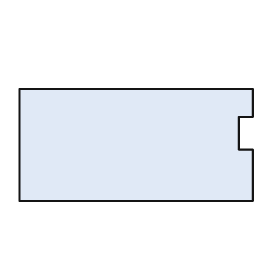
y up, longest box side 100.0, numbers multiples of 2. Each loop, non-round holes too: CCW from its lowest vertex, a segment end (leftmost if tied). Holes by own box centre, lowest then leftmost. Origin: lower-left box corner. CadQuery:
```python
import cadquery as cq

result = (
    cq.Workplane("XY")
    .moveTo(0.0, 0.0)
    .lineTo(100.0, 0.0)
    .lineTo(100.0, 22.0)
    .lineTo(94.0, 22.0)
    .lineTo(94.0, 36.0)
    .lineTo(100.0, 36.0)
    .lineTo(100.0, 48.0)
    .lineTo(0.0, 48.0)
    .close()
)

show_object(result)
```